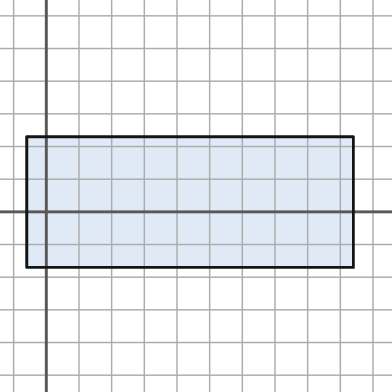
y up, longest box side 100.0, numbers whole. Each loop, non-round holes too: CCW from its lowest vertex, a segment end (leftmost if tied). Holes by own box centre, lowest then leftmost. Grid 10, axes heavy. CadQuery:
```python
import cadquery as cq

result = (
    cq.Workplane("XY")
    .moveTo(-6.0, -17.0)
    .lineTo(94.0, -17.0)
    .lineTo(94.0, 23.0)
    .lineTo(-6.0, 23.0)
    .close()
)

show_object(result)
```